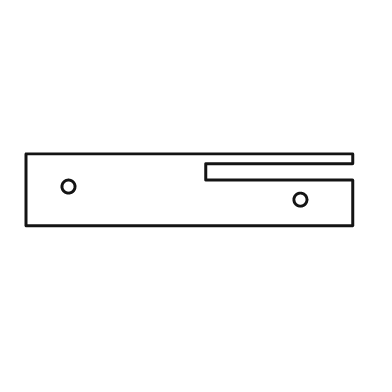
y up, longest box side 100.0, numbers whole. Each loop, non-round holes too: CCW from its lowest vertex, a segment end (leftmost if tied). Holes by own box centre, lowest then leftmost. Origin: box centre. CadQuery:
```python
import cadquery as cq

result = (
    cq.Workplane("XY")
    .moveTo(-50.0, -11.0)
    .lineTo(50.0, -11.0)
    .lineTo(50.0, 3.0)
    .lineTo(5.0, 3.0)
    .lineTo(5.0, 8.0)
    .lineTo(50.0, 8.0)
    .lineTo(50.0, 11.0)
    .lineTo(-50.0, 11.0)
    .close()
    .moveTo(34.0, -3.0)
    .circle(2.0)
    .moveTo(-37.0, 1.0)
    .circle(2.0)
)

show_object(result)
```